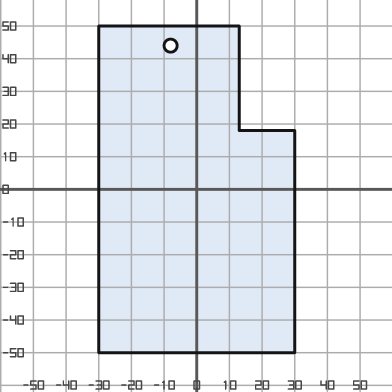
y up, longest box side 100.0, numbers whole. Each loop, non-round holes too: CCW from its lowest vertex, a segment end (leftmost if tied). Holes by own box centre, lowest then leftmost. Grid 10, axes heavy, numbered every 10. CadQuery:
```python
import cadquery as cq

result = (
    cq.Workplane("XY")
    .moveTo(-30.0, -50.0)
    .lineTo(30.0, -50.0)
    .lineTo(30.0, 18.0)
    .lineTo(13.0, 18.0)
    .lineTo(13.0, 50.0)
    .lineTo(-30.0, 50.0)
    .close()
    .moveTo(-8.0, 44.0)
    .circle(2.0)
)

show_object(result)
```